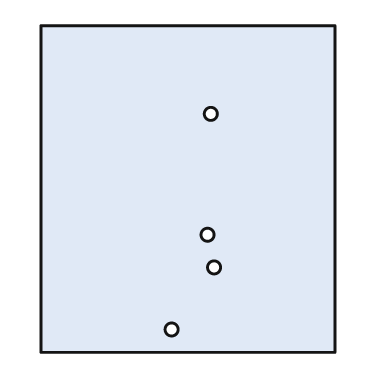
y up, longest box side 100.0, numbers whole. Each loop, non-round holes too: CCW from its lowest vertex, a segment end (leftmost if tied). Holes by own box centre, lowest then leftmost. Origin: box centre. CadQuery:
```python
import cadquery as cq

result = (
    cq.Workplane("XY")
    .moveTo(-45.0, -50.0)
    .lineTo(45.0, -50.0)
    .lineTo(45.0, 50.0)
    .lineTo(-45.0, 50.0)
    .close()
    .moveTo(-5.0, -43.0)
    .circle(2.0)
    .moveTo(8.0, -24.0)
    .circle(2.0)
    .moveTo(6.0, -14.0)
    .circle(2.0)
    .moveTo(7.0, 23.0)
    .circle(2.0)
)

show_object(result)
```